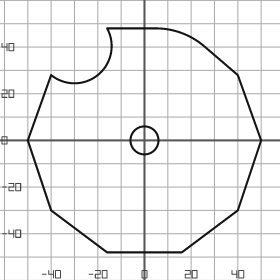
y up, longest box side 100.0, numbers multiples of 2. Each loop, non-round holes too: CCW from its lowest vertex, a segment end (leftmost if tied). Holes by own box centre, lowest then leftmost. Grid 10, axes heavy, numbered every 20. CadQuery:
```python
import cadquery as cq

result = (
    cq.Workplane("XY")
    .moveTo(-16.0, -48.0)
    .lineTo(16.0, -48.0)
    .lineTo(40.0, -30.0)
    .lineTo(50.0, 0.0)
    .lineTo(40.0, 28.0)
    .lineTo(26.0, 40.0)
    .threePointArc((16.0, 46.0), (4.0, 48.0))
    .lineTo(-16.0, 48.0)
    .threePointArc((-20.0, 28.0), (-40.0, 28.0))
    .lineTo(-50.0, 0.0)
    .lineTo(-40.0, -30.0)
    .close()
    .moveTo(0.0, 0.0)
    .circle(6.0)
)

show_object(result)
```